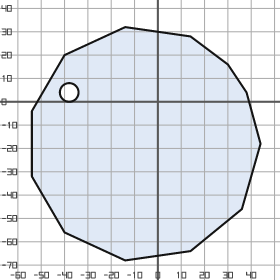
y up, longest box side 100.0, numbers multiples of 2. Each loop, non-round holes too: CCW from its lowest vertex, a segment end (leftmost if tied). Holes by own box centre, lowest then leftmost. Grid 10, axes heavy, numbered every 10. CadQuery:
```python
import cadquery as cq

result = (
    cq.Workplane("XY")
    .moveTo(-14.0, -68.0)
    .lineTo(14.0, -64.0)
    .lineTo(36.0, -46.0)
    .lineTo(44.0, -18.0)
    .lineTo(38.0, 4.0)
    .lineTo(30.0, 16.0)
    .lineTo(14.0, 28.0)
    .lineTo(-14.0, 32.0)
    .lineTo(-40.0, 20.0)
    .lineTo(-54.0, -4.0)
    .lineTo(-54.0, -32.0)
    .lineTo(-40.0, -56.0)
    .close()
    .moveTo(-38.0, 4.0)
    .circle(4.0)
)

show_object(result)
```